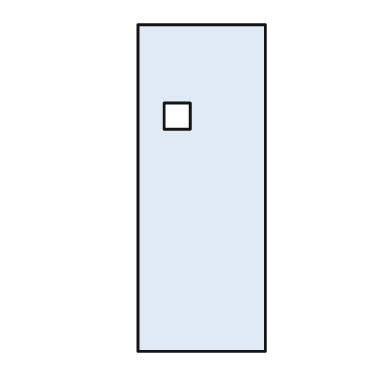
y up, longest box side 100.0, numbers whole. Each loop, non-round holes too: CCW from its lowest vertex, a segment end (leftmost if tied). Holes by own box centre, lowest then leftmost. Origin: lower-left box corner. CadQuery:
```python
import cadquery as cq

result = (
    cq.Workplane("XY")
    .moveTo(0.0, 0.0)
    .lineTo(39.0, 0.0)
    .lineTo(39.0, 100.0)
    .lineTo(0.0, 100.0)
    .close()
    .moveTo(8.0, 68.0)
    .lineTo(16.0, 68.0)
    .lineTo(16.0, 76.0)
    .lineTo(8.0, 76.0)
    .close()
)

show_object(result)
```